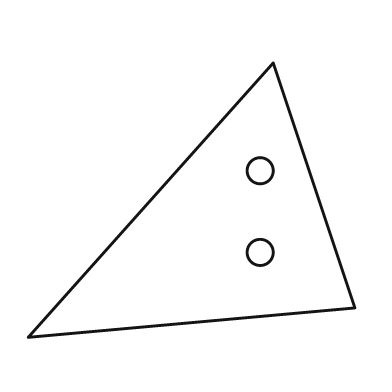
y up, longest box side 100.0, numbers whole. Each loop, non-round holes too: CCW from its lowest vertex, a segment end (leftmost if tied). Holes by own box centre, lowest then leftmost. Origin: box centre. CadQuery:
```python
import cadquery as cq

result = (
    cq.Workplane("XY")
    .moveTo(-50.0, -42.0)
    .lineTo(50.0, -33.0)
    .lineTo(25.0, 42.0)
    .close()
    .moveTo(21.0, -16.0)
    .circle(4.0)
    .moveTo(21.0, 9.0)
    .circle(4.0)
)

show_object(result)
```